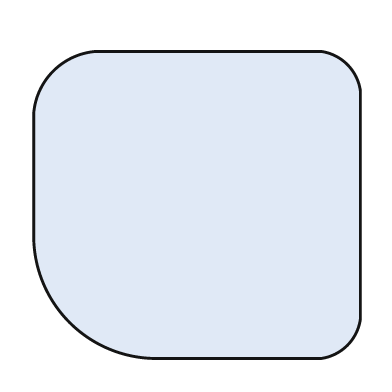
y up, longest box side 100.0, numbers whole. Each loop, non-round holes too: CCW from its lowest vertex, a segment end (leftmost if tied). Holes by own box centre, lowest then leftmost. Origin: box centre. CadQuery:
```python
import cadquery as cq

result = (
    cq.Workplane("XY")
    .moveTo(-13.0, -47.0)
    .lineTo(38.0, -47.0)
    .threePointArc((46.0, -43.0), (50.0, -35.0))
    .lineTo(50.0, 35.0)
    .threePointArc((46.0, 43.0), (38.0, 47.0))
    .lineTo(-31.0, 47.0)
    .threePointArc((-44.0, 41.0), (-50.0, 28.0))
    .lineTo(-50.0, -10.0)
    .threePointArc((-39.0, -36.0), (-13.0, -47.0))
    .close()
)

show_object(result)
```